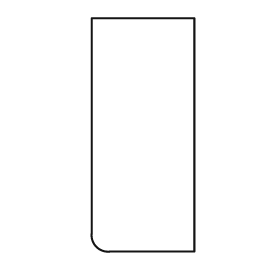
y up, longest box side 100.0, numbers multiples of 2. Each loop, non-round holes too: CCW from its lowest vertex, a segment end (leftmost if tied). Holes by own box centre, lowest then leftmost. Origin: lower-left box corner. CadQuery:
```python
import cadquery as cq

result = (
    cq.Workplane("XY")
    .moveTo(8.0, 0.0)
    .lineTo(44.0, 0.0)
    .lineTo(44.0, 100.0)
    .lineTo(0.0, 100.0)
    .lineTo(0.0, 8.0)
    .threePointArc((2.0, 2.0), (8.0, 0.0))
    .close()
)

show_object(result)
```